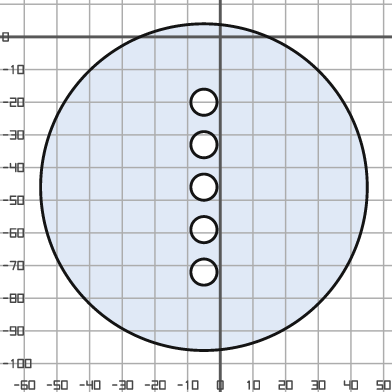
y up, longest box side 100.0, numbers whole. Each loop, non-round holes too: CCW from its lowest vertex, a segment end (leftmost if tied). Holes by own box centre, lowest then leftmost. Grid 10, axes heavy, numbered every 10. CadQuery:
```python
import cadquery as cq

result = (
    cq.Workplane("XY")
    .moveTo(-5.0, -46.0)
    .circle(50.0)
    .moveTo(-5.0, -72.0)
    .circle(4.0)
    .moveTo(-5.0, -59.0)
    .circle(4.0)
    .moveTo(-5.0, -46.0)
    .circle(4.0)
    .moveTo(-5.0, -33.0)
    .circle(4.0)
    .moveTo(-5.0, -20.0)
    .circle(4.0)
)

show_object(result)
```